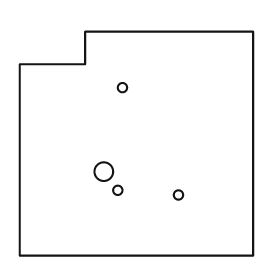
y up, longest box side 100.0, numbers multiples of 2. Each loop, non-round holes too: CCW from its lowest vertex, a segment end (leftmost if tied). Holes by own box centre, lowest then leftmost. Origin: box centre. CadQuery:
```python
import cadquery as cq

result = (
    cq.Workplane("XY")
    .moveTo(-50.0, -48.0)
    .lineTo(50.0, -48.0)
    .lineTo(50.0, 48.0)
    .lineTo(-22.0, 48.0)
    .lineTo(-22.0, 34.0)
    .lineTo(-50.0, 34.0)
    .close()
    .moveTo(18.0, -22.0)
    .circle(2.0)
    .moveTo(-8.0, -20.0)
    .circle(2.0)
    .moveTo(-14.0, -12.0)
    .circle(4.0)
    .moveTo(-6.0, 24.0)
    .circle(2.0)
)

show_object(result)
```